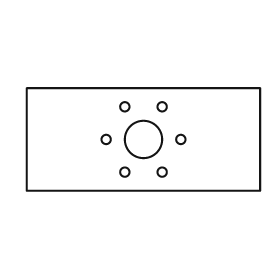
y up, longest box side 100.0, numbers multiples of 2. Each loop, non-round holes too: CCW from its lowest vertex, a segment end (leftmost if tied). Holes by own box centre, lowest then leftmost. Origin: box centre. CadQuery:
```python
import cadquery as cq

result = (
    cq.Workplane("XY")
    .moveTo(-50.0, -22.0)
    .lineTo(50.0, -22.0)
    .lineTo(50.0, 22.0)
    .lineTo(-50.0, 22.0)
    .close()
    .moveTo(-8.0, -14.0)
    .circle(2.0)
    .moveTo(8.0, -14.0)
    .circle(2.0)
    .moveTo(-16.0, 0.0)
    .circle(2.0)
    .moveTo(0.0, 0.0)
    .circle(8.0)
    .moveTo(16.0, 0.0)
    .circle(2.0)
    .moveTo(-8.0, 14.0)
    .circle(2.0)
    .moveTo(8.0, 14.0)
    .circle(2.0)
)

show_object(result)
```